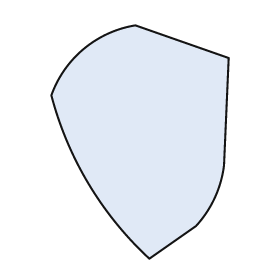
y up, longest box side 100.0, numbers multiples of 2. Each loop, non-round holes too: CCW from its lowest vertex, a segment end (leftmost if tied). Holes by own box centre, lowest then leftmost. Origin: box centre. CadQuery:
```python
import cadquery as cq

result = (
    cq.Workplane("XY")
    .moveTo(4.0, -50.0)
    .lineTo(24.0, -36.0)
    .threePointArc((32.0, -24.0), (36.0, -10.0))
    .lineTo(38.0, 36.0)
    .lineTo(-2.0, 50.0)
    .threePointArc((-24.0, 40.0), (-38.0, 20.0))
    .threePointArc((-22.0, -18.0), (4.0, -50.0))
    .close()
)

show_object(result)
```